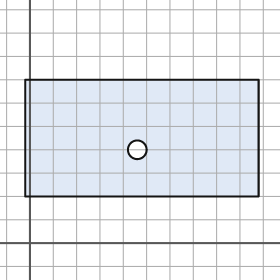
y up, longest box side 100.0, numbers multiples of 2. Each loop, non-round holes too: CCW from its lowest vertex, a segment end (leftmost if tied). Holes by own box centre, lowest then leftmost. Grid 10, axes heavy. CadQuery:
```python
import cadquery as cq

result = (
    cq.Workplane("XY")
    .moveTo(-2.0, 20.0)
    .lineTo(98.0, 20.0)
    .lineTo(98.0, 70.0)
    .lineTo(-2.0, 70.0)
    .close()
    .moveTo(46.0, 40.0)
    .circle(4.0)
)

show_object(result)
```